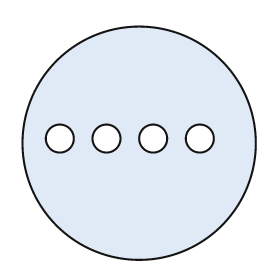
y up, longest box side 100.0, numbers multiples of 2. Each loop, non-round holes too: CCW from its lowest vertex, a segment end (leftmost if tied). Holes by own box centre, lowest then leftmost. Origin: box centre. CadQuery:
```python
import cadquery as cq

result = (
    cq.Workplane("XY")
    .moveTo(0.0, 0.0)
    .circle(50.0)
    .moveTo(-34.0, 2.0)
    .circle(6.0)
    .moveTo(-14.0, 2.0)
    .circle(6.0)
    .moveTo(6.0, 2.0)
    .circle(6.0)
    .moveTo(26.0, 2.0)
    .circle(6.0)
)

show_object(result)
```